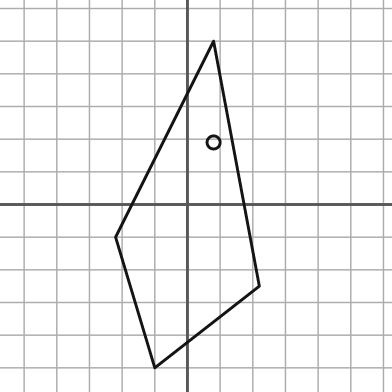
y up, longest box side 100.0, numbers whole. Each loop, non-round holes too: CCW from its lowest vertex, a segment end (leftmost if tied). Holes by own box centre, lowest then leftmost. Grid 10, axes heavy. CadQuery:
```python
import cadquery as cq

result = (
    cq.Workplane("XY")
    .moveTo(-10.0, -50.0)
    .lineTo(22.0, -25.0)
    .lineTo(8.0, 50.0)
    .lineTo(-22.0, -10.0)
    .close()
    .moveTo(8.0, 19.0)
    .circle(2.0)
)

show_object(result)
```